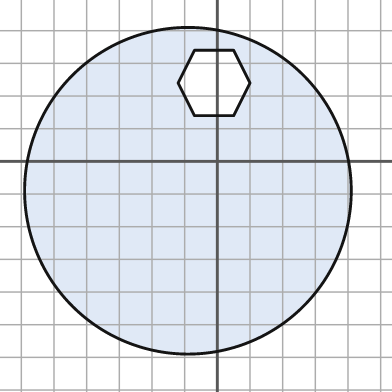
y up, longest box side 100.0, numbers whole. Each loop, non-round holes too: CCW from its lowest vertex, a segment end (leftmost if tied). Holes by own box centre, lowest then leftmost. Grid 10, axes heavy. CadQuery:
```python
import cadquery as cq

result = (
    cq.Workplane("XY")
    .moveTo(-9.0, -9.0)
    .circle(50.0)
    .moveTo(-7.0, 14.0)
    .lineTo(5.0, 14.0)
    .lineTo(10.0, 24.0)
    .lineTo(5.0, 34.0)
    .lineTo(-7.0, 34.0)
    .lineTo(-12.0, 24.0)
    .close()
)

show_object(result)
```